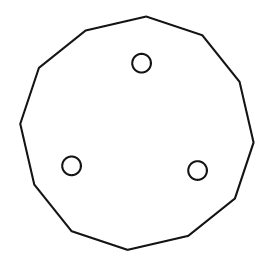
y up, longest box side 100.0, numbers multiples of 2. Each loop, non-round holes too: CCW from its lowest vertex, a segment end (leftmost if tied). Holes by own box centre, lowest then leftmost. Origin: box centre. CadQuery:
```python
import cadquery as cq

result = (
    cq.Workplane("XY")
    .moveTo(-4.0, -50.0)
    .lineTo(22.0, -44.0)
    .lineTo(42.0, -28.0)
    .lineTo(50.0, -4.0)
    .lineTo(44.0, 22.0)
    .lineTo(28.0, 42.0)
    .lineTo(4.0, 50.0)
    .lineTo(-22.0, 44.0)
    .lineTo(-42.0, 28.0)
    .lineTo(-50.0, 4.0)
    .lineTo(-44.0, -22.0)
    .lineTo(-28.0, -42.0)
    .close()
    .moveTo(26.0, -16.0)
    .circle(4.0)
    .moveTo(-28.0, -14.0)
    .circle(4.0)
    .moveTo(2.0, 30.0)
    .circle(4.0)
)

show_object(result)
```